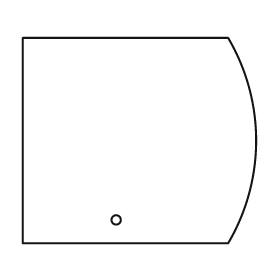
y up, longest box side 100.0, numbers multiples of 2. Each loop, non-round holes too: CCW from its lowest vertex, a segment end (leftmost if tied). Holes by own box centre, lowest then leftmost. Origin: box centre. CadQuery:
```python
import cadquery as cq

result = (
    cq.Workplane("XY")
    .moveTo(-50.0, -44.0)
    .lineTo(38.0, -44.0)
    .threePointArc((50.0, 0.0), (38.0, 44.0))
    .lineTo(-50.0, 44.0)
    .close()
    .moveTo(-10.0, -34.0)
    .circle(2.0)
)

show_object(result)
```